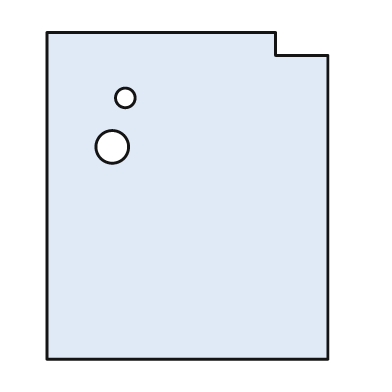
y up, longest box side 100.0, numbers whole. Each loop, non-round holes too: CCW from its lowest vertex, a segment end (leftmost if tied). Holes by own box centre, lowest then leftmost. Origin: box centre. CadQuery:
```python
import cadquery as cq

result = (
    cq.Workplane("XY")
    .moveTo(-43.0, -50.0)
    .lineTo(43.0, -50.0)
    .lineTo(43.0, 43.0)
    .lineTo(27.0, 43.0)
    .lineTo(27.0, 50.0)
    .lineTo(-43.0, 50.0)
    .close()
    .moveTo(-23.0, 15.0)
    .circle(5.0)
    .moveTo(-19.0, 30.0)
    .circle(3.0)
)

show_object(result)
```